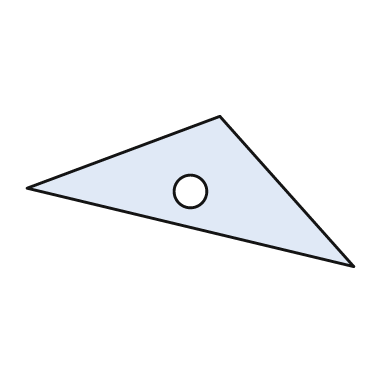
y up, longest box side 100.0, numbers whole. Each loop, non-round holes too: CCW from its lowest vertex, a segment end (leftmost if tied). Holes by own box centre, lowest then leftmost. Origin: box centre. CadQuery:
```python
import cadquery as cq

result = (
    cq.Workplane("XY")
    .moveTo(50.0, -23.0)
    .lineTo(9.0, 23.0)
    .lineTo(-50.0, 1.0)
    .close()
    .moveTo(0.0, 0.0)
    .circle(5.0)
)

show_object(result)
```